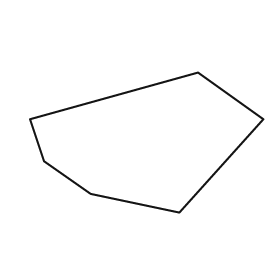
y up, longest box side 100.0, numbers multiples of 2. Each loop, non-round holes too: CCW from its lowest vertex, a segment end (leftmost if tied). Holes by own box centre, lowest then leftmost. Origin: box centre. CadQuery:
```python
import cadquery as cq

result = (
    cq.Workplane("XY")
    .moveTo(14.0, -30.0)
    .lineTo(50.0, 10.0)
    .lineTo(22.0, 30.0)
    .lineTo(-50.0, 10.0)
    .lineTo(-44.0, -8.0)
    .lineTo(-24.0, -22.0)
    .close()
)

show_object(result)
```